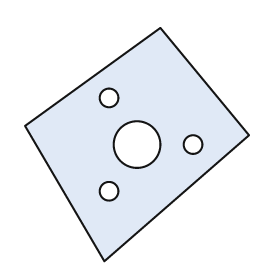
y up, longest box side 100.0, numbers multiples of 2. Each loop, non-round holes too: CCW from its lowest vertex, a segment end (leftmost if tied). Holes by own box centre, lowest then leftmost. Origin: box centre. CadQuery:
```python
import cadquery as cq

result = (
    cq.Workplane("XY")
    .moveTo(-14.0, -50.0)
    .lineTo(48.0, 4.0)
    .lineTo(10.0, 50.0)
    .lineTo(-48.0, 8.0)
    .close()
    .moveTo(-12.0, -20.0)
    .circle(4.0)
    .moveTo(0.0, 0.0)
    .circle(10.0)
    .moveTo(24.0, 0.0)
    .circle(4.0)
    .moveTo(-12.0, 20.0)
    .circle(4.0)
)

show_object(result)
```